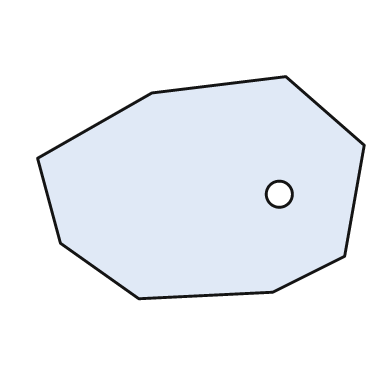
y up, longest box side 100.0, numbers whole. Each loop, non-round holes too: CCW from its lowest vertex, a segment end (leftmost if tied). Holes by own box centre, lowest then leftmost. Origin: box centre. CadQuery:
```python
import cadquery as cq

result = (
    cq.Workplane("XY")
    .moveTo(-19.0, -34.0)
    .lineTo(22.0, -32.0)
    .lineTo(44.0, -21.0)
    .lineTo(50.0, 13.0)
    .lineTo(26.0, 34.0)
    .lineTo(-15.0, 29.0)
    .lineTo(-50.0, 9.0)
    .lineTo(-43.0, -17.0)
    .close()
    .moveTo(24.0, -2.0)
    .circle(4.0)
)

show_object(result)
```